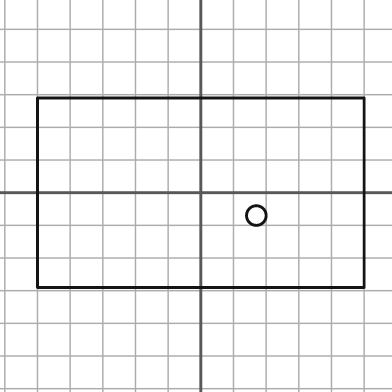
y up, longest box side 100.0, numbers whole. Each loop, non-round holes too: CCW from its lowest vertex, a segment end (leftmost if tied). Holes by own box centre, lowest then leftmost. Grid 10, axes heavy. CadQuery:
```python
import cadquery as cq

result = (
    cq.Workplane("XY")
    .moveTo(-50.0, -29.0)
    .lineTo(50.0, -29.0)
    .lineTo(50.0, 29.0)
    .lineTo(-50.0, 29.0)
    .close()
    .moveTo(17.0, -7.0)
    .circle(3.0)
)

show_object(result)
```